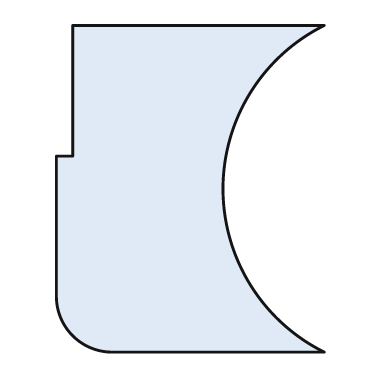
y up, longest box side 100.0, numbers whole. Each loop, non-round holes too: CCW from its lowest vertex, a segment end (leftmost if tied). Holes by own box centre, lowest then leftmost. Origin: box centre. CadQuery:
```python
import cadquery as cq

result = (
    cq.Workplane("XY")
    .moveTo(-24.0, -50.0)
    .lineTo(41.0, -50.0)
    .threePointArc((10.0, 0.0), (41.0, 50.0))
    .lineTo(-36.0, 50.0)
    .lineTo(-36.0, 10.0)
    .lineTo(-41.0, 10.0)
    .lineTo(-41.0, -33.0)
    .threePointArc((-36.0, -45.0), (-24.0, -50.0))
    .close()
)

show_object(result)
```